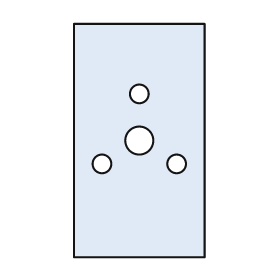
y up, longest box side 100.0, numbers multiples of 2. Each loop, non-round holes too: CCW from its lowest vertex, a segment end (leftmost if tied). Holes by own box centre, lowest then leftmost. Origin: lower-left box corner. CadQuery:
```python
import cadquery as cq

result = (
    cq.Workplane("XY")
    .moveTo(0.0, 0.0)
    .lineTo(56.0, 0.0)
    .lineTo(56.0, 100.0)
    .lineTo(0.0, 100.0)
    .close()
    .moveTo(12.0, 40.0)
    .circle(4.0)
    .moveTo(44.0, 40.0)
    .circle(4.0)
    .moveTo(28.0, 50.0)
    .circle(6.0)
    .moveTo(28.0, 70.0)
    .circle(4.0)
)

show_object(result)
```